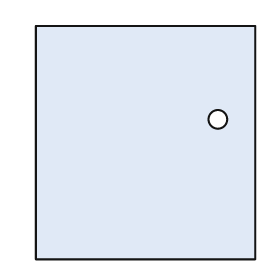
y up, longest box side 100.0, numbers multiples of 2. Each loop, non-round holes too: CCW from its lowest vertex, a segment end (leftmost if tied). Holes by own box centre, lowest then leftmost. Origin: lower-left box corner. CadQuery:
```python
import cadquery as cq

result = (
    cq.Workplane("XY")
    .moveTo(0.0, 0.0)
    .lineTo(94.0, 0.0)
    .lineTo(94.0, 100.0)
    .lineTo(0.0, 100.0)
    .close()
    .moveTo(78.0, 60.0)
    .circle(4.0)
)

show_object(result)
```